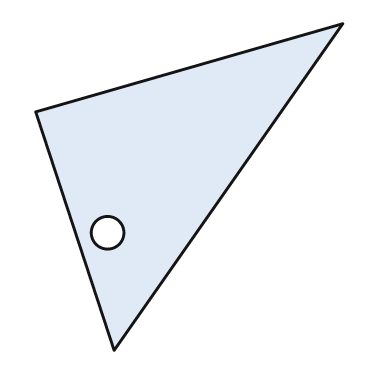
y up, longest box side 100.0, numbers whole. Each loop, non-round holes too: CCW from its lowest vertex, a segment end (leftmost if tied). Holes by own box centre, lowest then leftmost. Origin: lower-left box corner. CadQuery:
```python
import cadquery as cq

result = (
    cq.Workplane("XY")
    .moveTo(24.0, 0.0)
    .lineTo(94.0, 100.0)
    .lineTo(0.0, 73.0)
    .close()
    .moveTo(22.0, 36.0)
    .circle(5.0)
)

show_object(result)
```